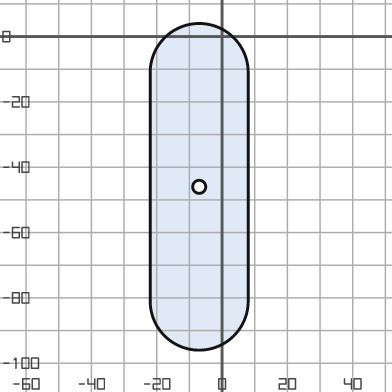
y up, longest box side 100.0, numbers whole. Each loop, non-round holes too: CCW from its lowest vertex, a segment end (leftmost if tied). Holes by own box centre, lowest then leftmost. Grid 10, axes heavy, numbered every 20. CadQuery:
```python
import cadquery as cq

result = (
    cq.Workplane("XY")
    .moveTo(-22.0, -81.0)
    .threePointArc((-7.0, -96.0), (8.0, -81.0))
    .lineTo(8.0, -11.0)
    .threePointArc((-7.0, 4.0), (-22.0, -11.0))
    .close()
    .moveTo(-7.0, -46.0)
    .circle(2.0)
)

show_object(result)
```